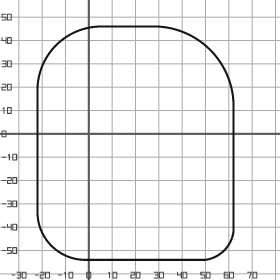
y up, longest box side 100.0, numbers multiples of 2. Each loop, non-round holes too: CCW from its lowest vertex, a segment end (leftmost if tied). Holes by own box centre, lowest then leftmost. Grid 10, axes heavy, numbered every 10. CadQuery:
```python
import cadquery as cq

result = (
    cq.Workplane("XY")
    .moveTo(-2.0, -54.0)
    .lineTo(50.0, -54.0)
    .threePointArc((58.0, -50.0), (62.0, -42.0))
    .lineTo(62.0, 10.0)
    .threePointArc((52.0, 36.0), (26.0, 46.0))
    .lineTo(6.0, 46.0)
    .threePointArc((-14.0, 38.0), (-22.0, 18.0))
    .lineTo(-22.0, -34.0)
    .threePointArc((-16.0, -48.0), (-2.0, -54.0))
    .close()
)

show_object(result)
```